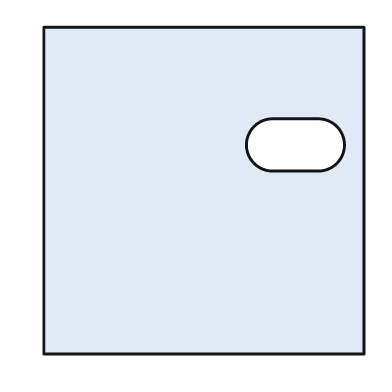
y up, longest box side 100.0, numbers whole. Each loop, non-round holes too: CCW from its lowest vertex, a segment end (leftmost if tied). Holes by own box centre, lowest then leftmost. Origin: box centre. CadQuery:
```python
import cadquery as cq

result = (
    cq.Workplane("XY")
    .moveTo(-49.0, -50.0)
    .lineTo(49.0, -50.0)
    .lineTo(49.0, 50.0)
    .lineTo(-49.0, 50.0)
    .close()
    .moveTo(21.0, 6.0)
    .lineTo(35.0, 6.0)
    .threePointArc((43.0, 14.0), (35.0, 22.0))
    .lineTo(21.0, 22.0)
    .threePointArc((13.0, 14.0), (21.0, 6.0))
    .close()
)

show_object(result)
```